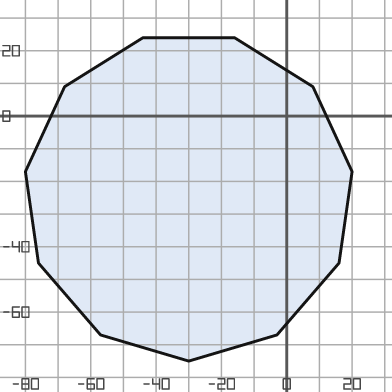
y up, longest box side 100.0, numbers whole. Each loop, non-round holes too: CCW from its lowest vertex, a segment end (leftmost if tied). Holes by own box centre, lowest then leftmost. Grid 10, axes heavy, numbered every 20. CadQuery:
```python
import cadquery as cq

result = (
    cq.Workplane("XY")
    .moveTo(-30.0, -75.0)
    .lineTo(-3.0, -67.0)
    .lineTo(16.0, -45.0)
    .lineTo(20.0, -17.0)
    .lineTo(8.0, 9.0)
    .lineTo(-16.0, 24.0)
    .lineTo(-44.0, 24.0)
    .lineTo(-68.0, 9.0)
    .lineTo(-80.0, -17.0)
    .lineTo(-76.0, -45.0)
    .lineTo(-57.0, -67.0)
    .close()
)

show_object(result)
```